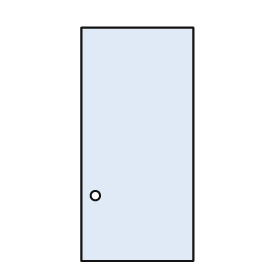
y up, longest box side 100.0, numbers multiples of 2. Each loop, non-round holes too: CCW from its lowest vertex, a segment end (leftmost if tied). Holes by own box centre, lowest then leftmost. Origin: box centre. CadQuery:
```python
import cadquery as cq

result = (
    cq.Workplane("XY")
    .moveTo(-24.0, -50.0)
    .lineTo(24.0, -50.0)
    .lineTo(24.0, 50.0)
    .lineTo(-24.0, 50.0)
    .close()
    .moveTo(-18.0, -22.0)
    .circle(2.0)
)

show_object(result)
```